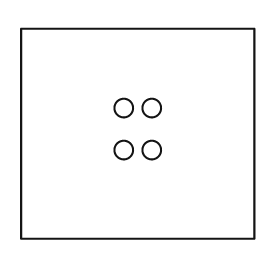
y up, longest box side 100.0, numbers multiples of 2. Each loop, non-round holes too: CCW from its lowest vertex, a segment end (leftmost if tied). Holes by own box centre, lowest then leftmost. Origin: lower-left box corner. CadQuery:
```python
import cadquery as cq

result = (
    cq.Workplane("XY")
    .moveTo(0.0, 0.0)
    .lineTo(100.0, 0.0)
    .lineTo(100.0, 90.0)
    .lineTo(0.0, 90.0)
    .close()
    .moveTo(44.0, 38.0)
    .circle(4.0)
    .moveTo(56.0, 38.0)
    .circle(4.0)
    .moveTo(44.0, 56.0)
    .circle(4.0)
    .moveTo(56.0, 56.0)
    .circle(4.0)
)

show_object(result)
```